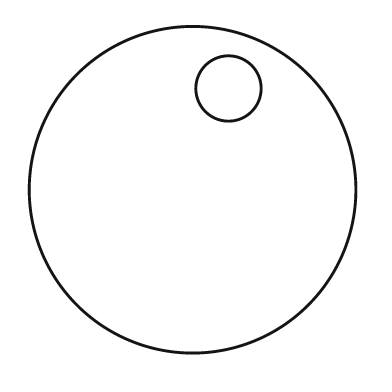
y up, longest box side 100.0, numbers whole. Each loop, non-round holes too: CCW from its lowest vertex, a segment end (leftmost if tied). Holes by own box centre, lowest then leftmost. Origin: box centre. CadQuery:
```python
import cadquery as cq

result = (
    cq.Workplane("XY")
    .moveTo(0.0, 0.0)
    .circle(50.0)
    .moveTo(11.0, 31.0)
    .circle(10.0)
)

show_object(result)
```